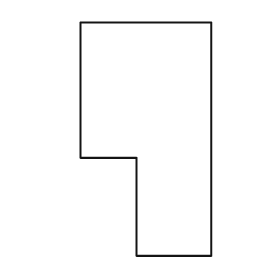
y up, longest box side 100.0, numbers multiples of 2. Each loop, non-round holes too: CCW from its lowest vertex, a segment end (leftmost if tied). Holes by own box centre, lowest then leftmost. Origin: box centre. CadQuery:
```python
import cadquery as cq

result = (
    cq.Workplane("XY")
    .moveTo(-4.0, -50.0)
    .lineTo(28.0, -50.0)
    .lineTo(28.0, 50.0)
    .lineTo(-28.0, 50.0)
    .lineTo(-28.0, -8.0)
    .lineTo(-4.0, -8.0)
    .close()
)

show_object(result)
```